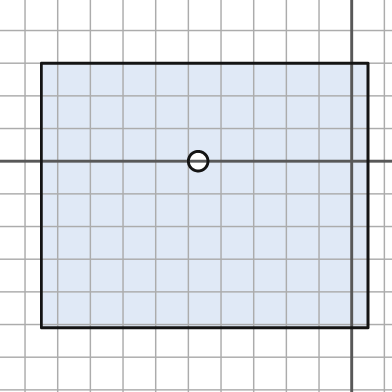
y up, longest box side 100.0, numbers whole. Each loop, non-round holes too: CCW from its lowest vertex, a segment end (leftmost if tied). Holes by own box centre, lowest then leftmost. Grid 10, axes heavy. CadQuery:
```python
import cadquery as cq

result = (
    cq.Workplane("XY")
    .moveTo(-95.0, -51.0)
    .lineTo(5.0, -51.0)
    .lineTo(5.0, 30.0)
    .lineTo(-95.0, 30.0)
    .close()
    .moveTo(-47.0, 0.0)
    .circle(3.0)
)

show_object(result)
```